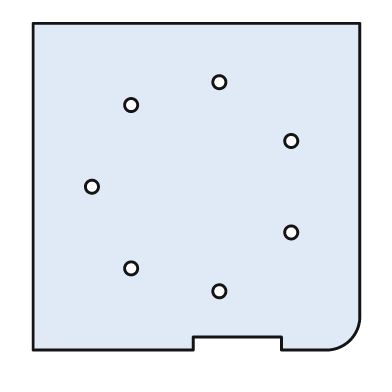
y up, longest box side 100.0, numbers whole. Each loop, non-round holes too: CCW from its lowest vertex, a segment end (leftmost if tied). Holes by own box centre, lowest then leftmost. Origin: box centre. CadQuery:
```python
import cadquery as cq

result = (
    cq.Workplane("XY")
    .moveTo(-50.0, -50.0)
    .lineTo(-1.0, -50.0)
    .lineTo(-1.0, -46.0)
    .lineTo(26.0, -46.0)
    .lineTo(26.0, -50.0)
    .lineTo(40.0, -50.0)
    .threePointArc((47.0, -47.0), (50.0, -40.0))
    .lineTo(50.0, 50.0)
    .lineTo(-50.0, 50.0)
    .close()
    .moveTo(7.0, -32.0)
    .circle(2.0)
    .moveTo(-20.0, -25.0)
    .circle(2.0)
    .moveTo(29.0, -14.0)
    .circle(2.0)
    .moveTo(-32.0, 0.0)
    .circle(2.0)
    .moveTo(29.0, 14.0)
    .circle(2.0)
    .moveTo(-20.0, 25.0)
    .circle(2.0)
    .moveTo(7.0, 32.0)
    .circle(2.0)
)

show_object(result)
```